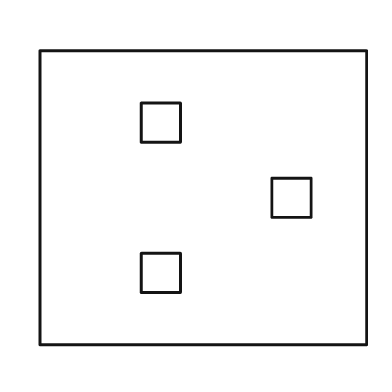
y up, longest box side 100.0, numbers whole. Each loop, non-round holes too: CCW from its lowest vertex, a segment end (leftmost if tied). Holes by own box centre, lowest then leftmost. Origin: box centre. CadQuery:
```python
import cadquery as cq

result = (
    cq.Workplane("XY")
    .moveTo(-50.0, -45.0)
    .lineTo(50.0, -45.0)
    .lineTo(50.0, 45.0)
    .lineTo(-50.0, 45.0)
    .close()
    .moveTo(-19.0, -29.0)
    .lineTo(-7.0, -29.0)
    .lineTo(-7.0, -17.0)
    .lineTo(-19.0, -17.0)
    .close()
    .moveTo(21.0, -6.0)
    .lineTo(33.0, -6.0)
    .lineTo(33.0, 6.0)
    .lineTo(21.0, 6.0)
    .close()
    .moveTo(-19.0, 17.0)
    .lineTo(-7.0, 17.0)
    .lineTo(-7.0, 29.0)
    .lineTo(-19.0, 29.0)
    .close()
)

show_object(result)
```